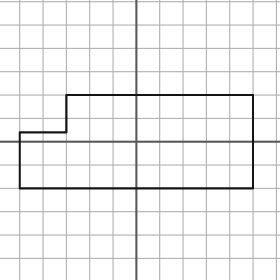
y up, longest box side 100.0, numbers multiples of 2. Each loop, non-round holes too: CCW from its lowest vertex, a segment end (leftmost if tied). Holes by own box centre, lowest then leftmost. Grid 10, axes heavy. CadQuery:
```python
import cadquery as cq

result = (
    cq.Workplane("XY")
    .moveTo(-50.0, -20.0)
    .lineTo(50.0, -20.0)
    .lineTo(50.0, 20.0)
    .lineTo(-30.0, 20.0)
    .lineTo(-30.0, 4.0)
    .lineTo(-50.0, 4.0)
    .close()
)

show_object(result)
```